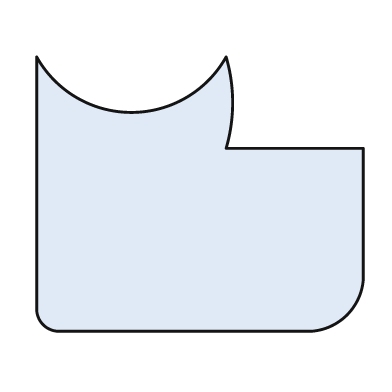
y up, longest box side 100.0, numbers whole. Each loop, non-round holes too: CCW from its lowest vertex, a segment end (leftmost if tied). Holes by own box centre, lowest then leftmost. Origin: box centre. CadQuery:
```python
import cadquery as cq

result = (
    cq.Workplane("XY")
    .moveTo(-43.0, -42.0)
    .lineTo(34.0, -42.0)
    .threePointArc((45.0, -37.0), (50.0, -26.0))
    .lineTo(50.0, 14.0)
    .lineTo(8.0, 14.0)
    .threePointArc((10.0, 28.0), (8.0, 42.0))
    .threePointArc((-21.0, 25.0), (-50.0, 42.0))
    .lineTo(-50.0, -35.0)
    .threePointArc((-48.0, -40.0), (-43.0, -42.0))
    .close()
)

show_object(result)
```